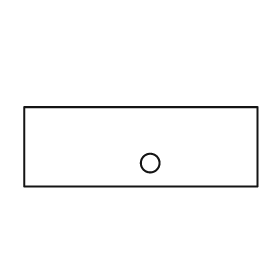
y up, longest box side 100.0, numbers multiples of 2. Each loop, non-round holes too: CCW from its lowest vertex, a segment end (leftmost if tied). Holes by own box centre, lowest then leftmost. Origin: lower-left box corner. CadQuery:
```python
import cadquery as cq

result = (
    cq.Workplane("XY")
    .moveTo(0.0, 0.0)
    .lineTo(100.0, 0.0)
    .lineTo(100.0, 34.0)
    .lineTo(0.0, 34.0)
    .close()
    .moveTo(54.0, 10.0)
    .circle(4.0)
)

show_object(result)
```